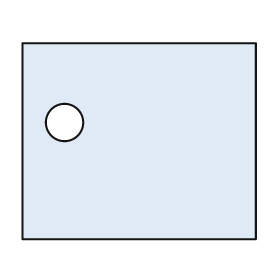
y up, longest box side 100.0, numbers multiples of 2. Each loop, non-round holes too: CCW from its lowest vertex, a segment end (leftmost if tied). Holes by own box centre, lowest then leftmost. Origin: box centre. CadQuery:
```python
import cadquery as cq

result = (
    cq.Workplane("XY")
    .moveTo(-50.0, -42.0)
    .lineTo(50.0, -42.0)
    .lineTo(50.0, 42.0)
    .lineTo(-50.0, 42.0)
    .close()
    .moveTo(-32.0, 8.0)
    .circle(8.0)
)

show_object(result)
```